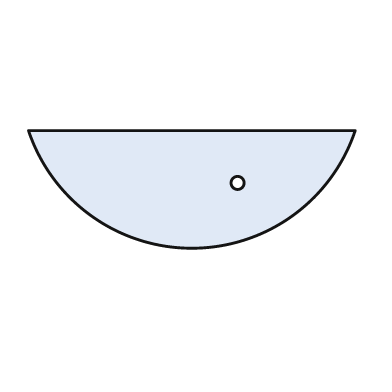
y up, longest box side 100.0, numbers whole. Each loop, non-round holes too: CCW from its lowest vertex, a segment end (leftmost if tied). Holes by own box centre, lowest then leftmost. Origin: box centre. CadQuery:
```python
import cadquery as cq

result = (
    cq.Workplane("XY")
    .moveTo(-50.0, 18.0)
    .threePointArc((0.0, -18.0), (50.0, 18.0))
    .close()
    .moveTo(14.0, 2.0)
    .circle(2.0)
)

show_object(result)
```